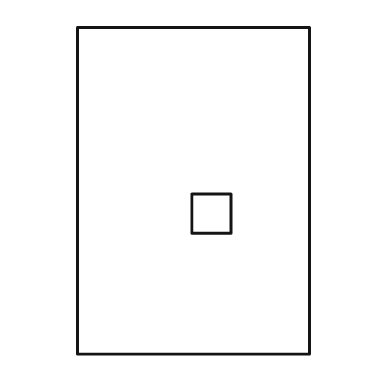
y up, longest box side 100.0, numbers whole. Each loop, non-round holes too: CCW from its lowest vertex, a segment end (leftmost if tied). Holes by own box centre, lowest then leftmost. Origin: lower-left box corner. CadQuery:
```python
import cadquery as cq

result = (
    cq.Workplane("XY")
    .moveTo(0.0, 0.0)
    .lineTo(71.0, 0.0)
    .lineTo(71.0, 100.0)
    .lineTo(0.0, 100.0)
    .close()
    .moveTo(35.0, 37.0)
    .lineTo(47.0, 37.0)
    .lineTo(47.0, 49.0)
    .lineTo(35.0, 49.0)
    .close()
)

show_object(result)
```